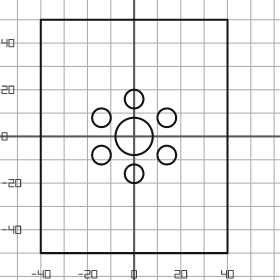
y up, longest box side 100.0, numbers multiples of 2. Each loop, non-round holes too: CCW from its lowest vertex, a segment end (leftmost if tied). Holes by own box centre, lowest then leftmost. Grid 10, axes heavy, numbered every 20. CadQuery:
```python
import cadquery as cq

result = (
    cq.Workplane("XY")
    .moveTo(-40.0, -50.0)
    .lineTo(40.0, -50.0)
    .lineTo(40.0, 50.0)
    .lineTo(-40.0, 50.0)
    .close()
    .moveTo(0.0, -16.0)
    .circle(4.0)
    .moveTo(-14.0, -8.0)
    .circle(4.0)
    .moveTo(14.0, -8.0)
    .circle(4.0)
    .moveTo(0.0, 0.0)
    .circle(8.0)
    .moveTo(-14.0, 8.0)
    .circle(4.0)
    .moveTo(14.0, 8.0)
    .circle(4.0)
    .moveTo(0.0, 16.0)
    .circle(4.0)
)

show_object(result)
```